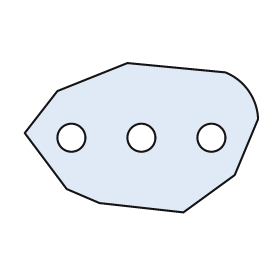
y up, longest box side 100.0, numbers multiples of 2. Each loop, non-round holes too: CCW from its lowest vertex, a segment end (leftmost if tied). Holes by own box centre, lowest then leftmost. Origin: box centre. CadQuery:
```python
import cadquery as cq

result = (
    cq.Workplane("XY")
    .moveTo(18.0, -32.0)
    .lineTo(40.0, -16.0)
    .lineTo(50.0, 8.0)
    .threePointArc((46.0, 20.0), (36.0, 28.0))
    .lineTo(-6.0, 32.0)
    .lineTo(-36.0, 20.0)
    .lineTo(-50.0, 2.0)
    .lineTo(-32.0, -22.0)
    .lineTo(-18.0, -28.0)
    .close()
    .moveTo(-30.0, 0.0)
    .circle(6.0)
    .moveTo(0.0, 0.0)
    .circle(6.0)
    .moveTo(30.0, 0.0)
    .circle(6.0)
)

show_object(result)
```